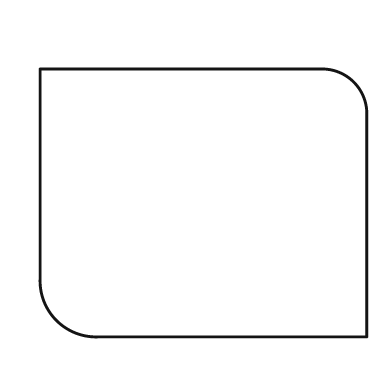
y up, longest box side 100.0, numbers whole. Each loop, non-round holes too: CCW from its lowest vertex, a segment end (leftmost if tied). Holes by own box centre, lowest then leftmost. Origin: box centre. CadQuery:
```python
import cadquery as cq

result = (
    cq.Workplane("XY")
    .moveTo(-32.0, -41.0)
    .lineTo(50.0, -41.0)
    .lineTo(50.0, 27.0)
    .threePointArc((46.0, 37.0), (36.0, 41.0))
    .lineTo(-50.0, 41.0)
    .lineTo(-50.0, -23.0)
    .threePointArc((-45.0, -36.0), (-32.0, -41.0))
    .close()
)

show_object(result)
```